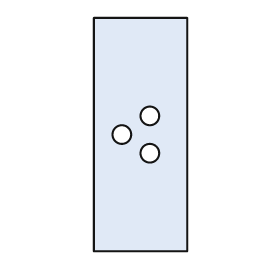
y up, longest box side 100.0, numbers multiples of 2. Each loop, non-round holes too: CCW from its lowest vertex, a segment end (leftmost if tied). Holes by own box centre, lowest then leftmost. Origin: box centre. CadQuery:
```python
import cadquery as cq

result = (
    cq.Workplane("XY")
    .moveTo(-20.0, -50.0)
    .lineTo(20.0, -50.0)
    .lineTo(20.0, 50.0)
    .lineTo(-20.0, 50.0)
    .close()
    .moveTo(4.0, -8.0)
    .circle(4.0)
    .moveTo(-8.0, 0.0)
    .circle(4.0)
    .moveTo(4.0, 8.0)
    .circle(4.0)
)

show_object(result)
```